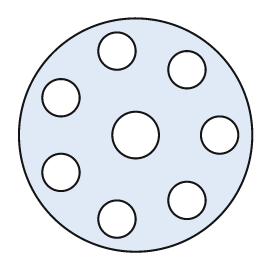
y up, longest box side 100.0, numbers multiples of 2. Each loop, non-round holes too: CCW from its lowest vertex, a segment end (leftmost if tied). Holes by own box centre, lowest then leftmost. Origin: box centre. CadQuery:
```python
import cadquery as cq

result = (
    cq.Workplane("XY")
    .moveTo(0.0, 0.0)
    .circle(50.0)
    .moveTo(-8.0, -36.0)
    .circle(8.0)
    .moveTo(22.0, -28.0)
    .circle(8.0)
    .moveTo(-32.0, -16.0)
    .circle(8.0)
    .moveTo(0.0, 0.0)
    .circle(10.0)
    .moveTo(36.0, 0.0)
    .circle(8.0)
    .moveTo(-32.0, 16.0)
    .circle(8.0)
    .moveTo(22.0, 28.0)
    .circle(8.0)
    .moveTo(-8.0, 36.0)
    .circle(8.0)
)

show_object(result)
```